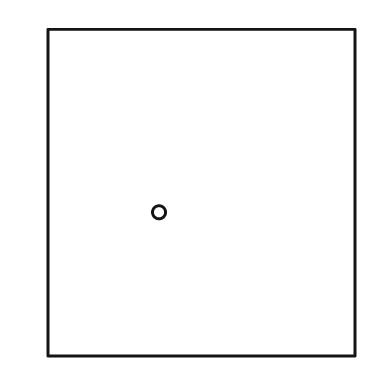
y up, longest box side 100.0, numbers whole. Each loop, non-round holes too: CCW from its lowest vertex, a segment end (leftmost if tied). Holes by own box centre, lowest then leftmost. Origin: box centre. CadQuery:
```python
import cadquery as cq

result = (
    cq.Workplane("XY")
    .moveTo(-47.0, -50.0)
    .lineTo(47.0, -50.0)
    .lineTo(47.0, 50.0)
    .lineTo(-47.0, 50.0)
    .close()
    .moveTo(-13.0, -6.0)
    .circle(2.0)
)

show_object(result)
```